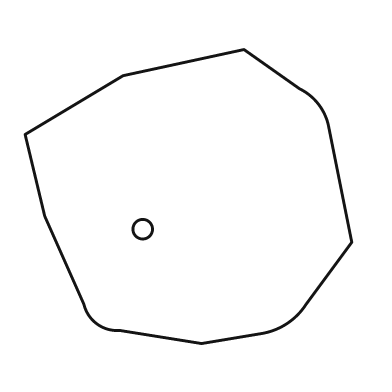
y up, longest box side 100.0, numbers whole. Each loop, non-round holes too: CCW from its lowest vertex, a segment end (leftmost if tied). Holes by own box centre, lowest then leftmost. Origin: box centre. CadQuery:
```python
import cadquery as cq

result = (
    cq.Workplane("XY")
    .moveTo(4.0, -45.0)
    .lineTo(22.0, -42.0)
    .threePointArc((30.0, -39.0), (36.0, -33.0))
    .lineTo(50.0, -14.0)
    .lineTo(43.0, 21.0)
    .threePointArc((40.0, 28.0), (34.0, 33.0))
    .lineTo(17.0, 45.0)
    .lineTo(-20.0, 37.0)
    .lineTo(-50.0, 19.0)
    .lineTo(-44.0, -6.0)
    .lineTo(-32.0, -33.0)
    .threePointArc((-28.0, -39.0), (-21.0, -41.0))
    .close()
    .moveTo(-14.0, -10.0)
    .circle(3.0)
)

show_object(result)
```